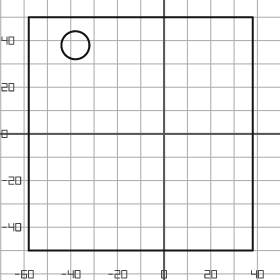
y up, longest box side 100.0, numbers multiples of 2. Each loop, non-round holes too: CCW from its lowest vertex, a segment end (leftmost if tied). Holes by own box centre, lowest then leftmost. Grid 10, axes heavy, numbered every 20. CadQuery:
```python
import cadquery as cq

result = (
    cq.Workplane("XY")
    .moveTo(-58.0, -50.0)
    .lineTo(38.0, -50.0)
    .lineTo(38.0, 50.0)
    .lineTo(-58.0, 50.0)
    .close()
    .moveTo(-38.0, 38.0)
    .circle(6.0)
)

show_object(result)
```